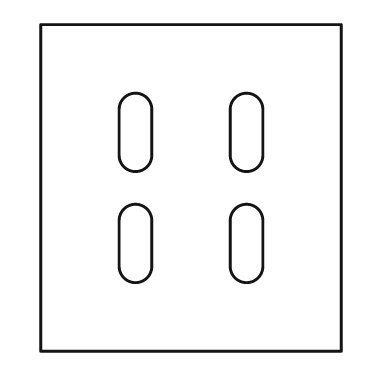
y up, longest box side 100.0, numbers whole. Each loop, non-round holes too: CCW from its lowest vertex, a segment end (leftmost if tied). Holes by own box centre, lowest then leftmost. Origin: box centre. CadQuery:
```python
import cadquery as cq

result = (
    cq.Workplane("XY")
    .moveTo(-46.0, -50.0)
    .lineTo(46.0, -50.0)
    .lineTo(46.0, 50.0)
    .lineTo(-46.0, 50.0)
    .close()
    .moveTo(-22.0, -24.0)
    .threePointArc((-17.0, -29.0), (-12.0, -24.0))
    .lineTo(-12.0, -10.0)
    .threePointArc((-17.0, -5.0), (-22.0, -10.0))
    .close()
    .moveTo(12.0, -24.0)
    .threePointArc((17.0, -29.0), (22.0, -24.0))
    .lineTo(22.0, -10.0)
    .threePointArc((17.0, -5.0), (12.0, -10.0))
    .close()
    .moveTo(-22.0, 10.0)
    .threePointArc((-17.0, 5.0), (-12.0, 10.0))
    .lineTo(-12.0, 24.0)
    .threePointArc((-17.0, 29.0), (-22.0, 24.0))
    .close()
    .moveTo(12.0, 10.0)
    .threePointArc((17.0, 5.0), (22.0, 10.0))
    .lineTo(22.0, 24.0)
    .threePointArc((17.0, 29.0), (12.0, 24.0))
    .close()
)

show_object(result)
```